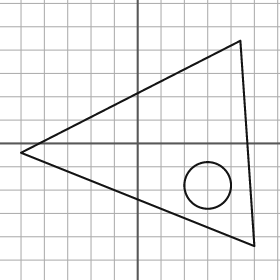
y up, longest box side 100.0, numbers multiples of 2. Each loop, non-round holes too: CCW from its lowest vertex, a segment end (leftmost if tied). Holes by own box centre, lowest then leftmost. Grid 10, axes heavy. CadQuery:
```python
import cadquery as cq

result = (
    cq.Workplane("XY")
    .moveTo(50.0, -44.0)
    .lineTo(44.0, 44.0)
    .lineTo(-50.0, -4.0)
    .close()
    .moveTo(30.0, -18.0)
    .circle(10.0)
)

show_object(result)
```